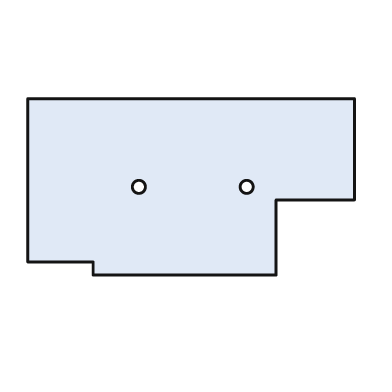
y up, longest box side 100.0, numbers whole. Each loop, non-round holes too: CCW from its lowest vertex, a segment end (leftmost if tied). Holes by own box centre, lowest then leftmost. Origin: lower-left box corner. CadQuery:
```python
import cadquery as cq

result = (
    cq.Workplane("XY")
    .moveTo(20.0, 0.0)
    .lineTo(76.0, 0.0)
    .lineTo(76.0, 23.0)
    .lineTo(100.0, 23.0)
    .lineTo(100.0, 54.0)
    .lineTo(0.0, 54.0)
    .lineTo(0.0, 4.0)
    .lineTo(20.0, 4.0)
    .close()
    .moveTo(34.0, 27.0)
    .circle(2.0)
    .moveTo(67.0, 27.0)
    .circle(2.0)
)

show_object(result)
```